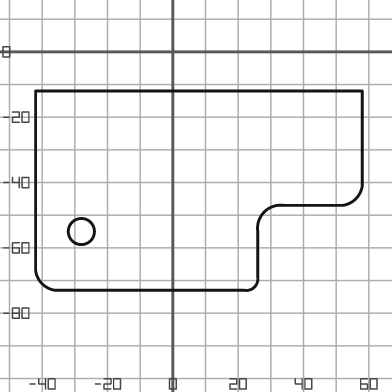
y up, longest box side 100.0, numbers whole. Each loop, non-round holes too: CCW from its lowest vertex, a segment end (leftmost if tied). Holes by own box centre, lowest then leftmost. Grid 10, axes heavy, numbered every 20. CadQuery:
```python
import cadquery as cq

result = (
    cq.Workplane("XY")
    .moveTo(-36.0, -73.0)
    .lineTo(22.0, -73.0)
    .threePointArc((25.0, -72.0), (26.0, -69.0))
    .lineTo(26.0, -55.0)
    .threePointArc((28.0, -49.0), (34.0, -47.0))
    .lineTo(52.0, -47.0)
    .threePointArc((56.0, -45.0), (58.0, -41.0))
    .lineTo(58.0, -12.0)
    .lineTo(-42.0, -12.0)
    .lineTo(-42.0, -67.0)
    .threePointArc((-40.0, -71.0), (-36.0, -73.0))
    .close()
    .moveTo(-28.0, -55.0)
    .circle(4.0)
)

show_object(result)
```